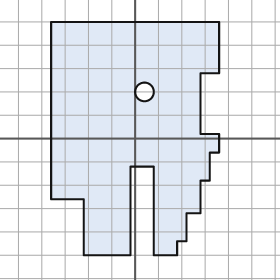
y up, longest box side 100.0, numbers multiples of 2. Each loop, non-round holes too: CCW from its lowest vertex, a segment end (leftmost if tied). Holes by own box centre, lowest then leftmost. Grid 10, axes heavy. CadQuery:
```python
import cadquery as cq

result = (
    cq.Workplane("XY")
    .moveTo(-22.0, -50.0)
    .lineTo(-2.0, -50.0)
    .lineTo(-2.0, -12.0)
    .lineTo(8.0, -12.0)
    .lineTo(8.0, -50.0)
    .lineTo(18.0, -50.0)
    .lineTo(18.0, -44.0)
    .lineTo(22.0, -44.0)
    .lineTo(22.0, -32.0)
    .lineTo(28.0, -32.0)
    .lineTo(28.0, -18.0)
    .lineTo(32.0, -18.0)
    .lineTo(32.0, -6.0)
    .lineTo(36.0, -6.0)
    .lineTo(36.0, 2.0)
    .lineTo(28.0, 2.0)
    .lineTo(28.0, 28.0)
    .lineTo(36.0, 28.0)
    .lineTo(36.0, 50.0)
    .lineTo(-36.0, 50.0)
    .lineTo(-36.0, -26.0)
    .lineTo(-22.0, -26.0)
    .close()
    .moveTo(4.0, 20.0)
    .circle(4.0)
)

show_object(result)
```